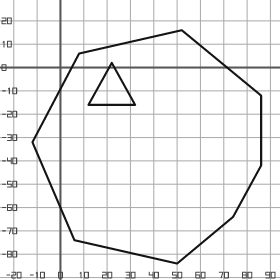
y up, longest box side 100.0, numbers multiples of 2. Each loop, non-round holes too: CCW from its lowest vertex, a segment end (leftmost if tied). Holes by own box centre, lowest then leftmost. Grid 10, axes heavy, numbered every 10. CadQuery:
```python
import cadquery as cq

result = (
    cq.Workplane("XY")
    .moveTo(50.0, -84.0)
    .lineTo(74.0, -64.0)
    .lineTo(86.0, -42.0)
    .lineTo(86.0, -12.0)
    .lineTo(52.0, 16.0)
    .lineTo(8.0, 6.0)
    .lineTo(-12.0, -32.0)
    .lineTo(6.0, -74.0)
    .close()
    .moveTo(12.0, -16.0)
    .lineTo(32.0, -16.0)
    .lineTo(22.0, 2.0)
    .close()
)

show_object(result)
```